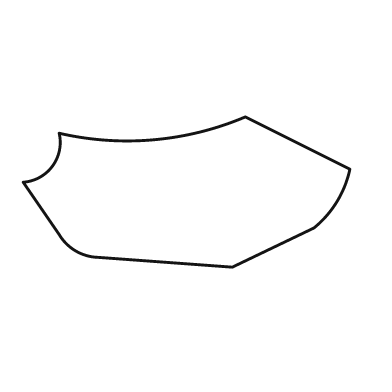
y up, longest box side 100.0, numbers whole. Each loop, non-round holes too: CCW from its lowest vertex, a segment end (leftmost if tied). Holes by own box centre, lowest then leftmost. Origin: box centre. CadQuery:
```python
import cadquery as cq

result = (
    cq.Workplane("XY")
    .moveTo(14.0, -23.0)
    .lineTo(39.0, -11.0)
    .threePointArc((46.0, -3.0), (50.0, 7.0))
    .lineTo(18.0, 23.0)
    .threePointArc((-10.0, 16.0), (-39.0, 18.0))
    .threePointArc((-41.0, 8.0), (-50.0, 3.0))
    .lineTo(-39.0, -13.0)
    .threePointArc((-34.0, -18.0), (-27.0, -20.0))
    .close()
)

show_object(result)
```